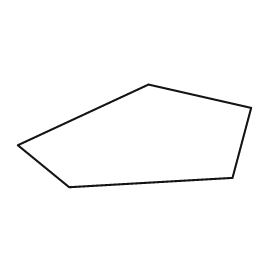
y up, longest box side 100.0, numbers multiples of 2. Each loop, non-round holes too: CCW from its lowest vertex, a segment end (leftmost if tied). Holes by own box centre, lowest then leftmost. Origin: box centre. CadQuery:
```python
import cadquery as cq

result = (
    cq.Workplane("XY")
    .moveTo(-28.0, -22.0)
    .lineTo(42.0, -18.0)
    .lineTo(50.0, 12.0)
    .lineTo(6.0, 22.0)
    .lineTo(-50.0, -4.0)
    .close()
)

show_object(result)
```